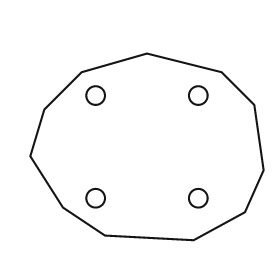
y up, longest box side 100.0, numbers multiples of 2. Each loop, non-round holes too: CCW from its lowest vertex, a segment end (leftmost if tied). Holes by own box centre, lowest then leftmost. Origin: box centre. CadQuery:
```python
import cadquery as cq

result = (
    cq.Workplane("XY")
    .moveTo(20.0, -40.0)
    .lineTo(42.0, -28.0)
    .lineTo(50.0, -10.0)
    .lineTo(46.0, 18.0)
    .lineTo(32.0, 32.0)
    .lineTo(0.0, 40.0)
    .lineTo(-28.0, 32.0)
    .lineTo(-44.0, 16.0)
    .lineTo(-50.0, -4.0)
    .lineTo(-36.0, -26.0)
    .lineTo(-18.0, -38.0)
    .close()
    .moveTo(-22.0, -22.0)
    .circle(4.0)
    .moveTo(22.0, -22.0)
    .circle(4.0)
    .moveTo(-22.0, 22.0)
    .circle(4.0)
    .moveTo(22.0, 22.0)
    .circle(4.0)
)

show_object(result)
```